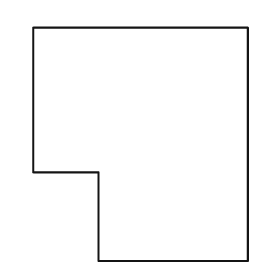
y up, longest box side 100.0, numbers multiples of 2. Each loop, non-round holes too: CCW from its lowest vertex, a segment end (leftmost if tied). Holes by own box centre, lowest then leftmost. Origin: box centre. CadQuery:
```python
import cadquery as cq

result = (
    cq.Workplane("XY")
    .moveTo(-18.0, -50.0)
    .lineTo(46.0, -50.0)
    .lineTo(46.0, 50.0)
    .lineTo(-46.0, 50.0)
    .lineTo(-46.0, -12.0)
    .lineTo(-18.0, -12.0)
    .close()
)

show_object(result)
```